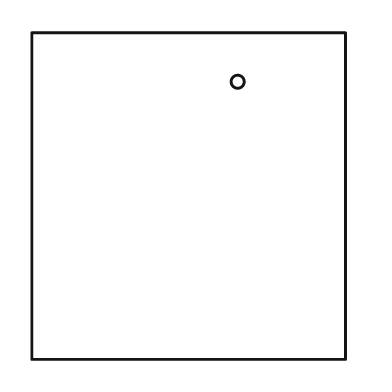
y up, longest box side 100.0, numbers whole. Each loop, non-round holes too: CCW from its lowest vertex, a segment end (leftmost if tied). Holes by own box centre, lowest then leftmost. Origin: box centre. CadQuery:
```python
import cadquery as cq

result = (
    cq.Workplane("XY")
    .moveTo(-48.0, -50.0)
    .lineTo(48.0, -50.0)
    .lineTo(48.0, 50.0)
    .lineTo(-48.0, 50.0)
    .close()
    .moveTo(15.0, 35.0)
    .circle(2.0)
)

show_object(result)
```